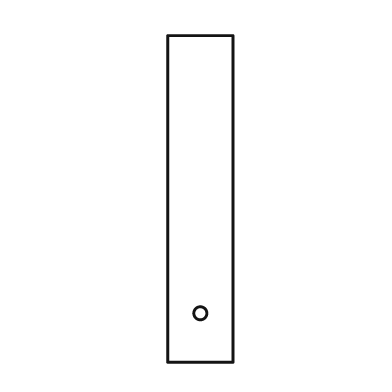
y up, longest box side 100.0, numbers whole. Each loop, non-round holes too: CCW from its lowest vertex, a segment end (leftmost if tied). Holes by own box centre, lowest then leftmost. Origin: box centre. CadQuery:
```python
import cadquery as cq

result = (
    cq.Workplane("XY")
    .moveTo(-10.0, -50.0)
    .lineTo(10.0, -50.0)
    .lineTo(10.0, 50.0)
    .lineTo(-10.0, 50.0)
    .close()
    .moveTo(0.0, -35.0)
    .circle(2.0)
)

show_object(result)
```